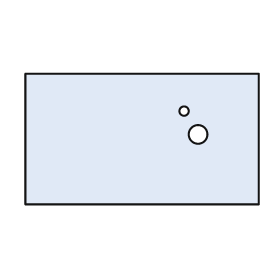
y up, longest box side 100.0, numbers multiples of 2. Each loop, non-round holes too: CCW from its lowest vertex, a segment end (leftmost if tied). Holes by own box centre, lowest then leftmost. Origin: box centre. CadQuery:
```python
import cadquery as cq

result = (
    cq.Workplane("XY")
    .moveTo(-50.0, -28.0)
    .lineTo(50.0, -28.0)
    .lineTo(50.0, 28.0)
    .lineTo(-50.0, 28.0)
    .close()
    .moveTo(24.0, 2.0)
    .circle(4.0)
    .moveTo(18.0, 12.0)
    .circle(2.0)
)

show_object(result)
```